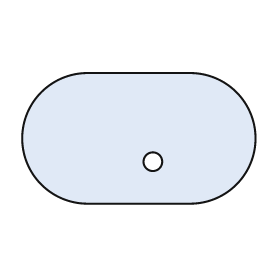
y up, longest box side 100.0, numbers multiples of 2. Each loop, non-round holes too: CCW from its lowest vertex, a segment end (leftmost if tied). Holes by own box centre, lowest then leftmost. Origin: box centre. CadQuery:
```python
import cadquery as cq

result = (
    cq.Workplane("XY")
    .moveTo(-22.0, -28.0)
    .lineTo(22.0, -28.0)
    .threePointArc((50.0, 0.0), (22.0, 28.0))
    .lineTo(-22.0, 28.0)
    .threePointArc((-50.0, 0.0), (-22.0, -28.0))
    .close()
    .moveTo(6.0, -10.0)
    .circle(4.0)
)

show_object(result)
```